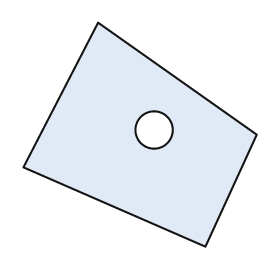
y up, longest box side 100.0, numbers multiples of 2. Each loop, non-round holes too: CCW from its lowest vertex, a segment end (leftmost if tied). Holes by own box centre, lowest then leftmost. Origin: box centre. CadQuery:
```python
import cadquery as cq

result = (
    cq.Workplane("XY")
    .moveTo(28.0, -48.0)
    .lineTo(50.0, 0.0)
    .lineTo(-18.0, 48.0)
    .lineTo(-50.0, -14.0)
    .close()
    .moveTo(6.0, 2.0)
    .circle(8.0)
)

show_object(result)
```